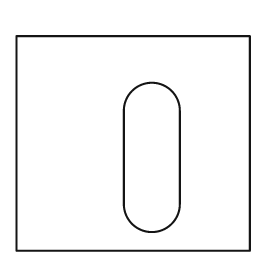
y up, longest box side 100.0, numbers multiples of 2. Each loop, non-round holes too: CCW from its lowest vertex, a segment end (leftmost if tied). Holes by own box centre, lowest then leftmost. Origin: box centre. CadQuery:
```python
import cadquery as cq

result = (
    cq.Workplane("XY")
    .moveTo(-50.0, -46.0)
    .lineTo(50.0, -46.0)
    .lineTo(50.0, 46.0)
    .lineTo(-50.0, 46.0)
    .close()
    .moveTo(-4.0, -26.0)
    .threePointArc((8.0, -38.0), (20.0, -26.0))
    .lineTo(20.0, 14.0)
    .threePointArc((8.0, 26.0), (-4.0, 14.0))
    .close()
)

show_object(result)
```